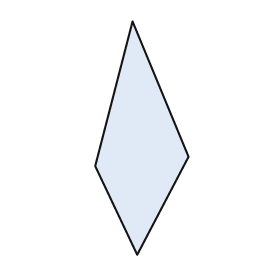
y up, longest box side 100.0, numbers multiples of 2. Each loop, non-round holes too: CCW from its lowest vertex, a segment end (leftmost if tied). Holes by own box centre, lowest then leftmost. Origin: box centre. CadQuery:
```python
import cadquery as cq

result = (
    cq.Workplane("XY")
    .moveTo(-2.0, -50.0)
    .lineTo(20.0, -8.0)
    .lineTo(-4.0, 50.0)
    .lineTo(-20.0, -12.0)
    .close()
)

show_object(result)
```